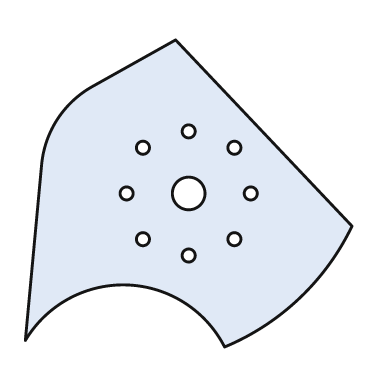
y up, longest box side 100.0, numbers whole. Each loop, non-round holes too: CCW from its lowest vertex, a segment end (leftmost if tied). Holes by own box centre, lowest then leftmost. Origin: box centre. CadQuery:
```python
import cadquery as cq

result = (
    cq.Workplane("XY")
    .moveTo(11.0, -47.0)
    .threePointArc((34.0, -32.0), (50.0, -10.0))
    .lineTo(-4.0, 47.0)
    .lineTo(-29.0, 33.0)
    .threePointArc((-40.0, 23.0), (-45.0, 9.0))
    .lineTo(-50.0, -45.0)
    .threePointArc((-19.0, -28.0), (11.0, -47.0))
    .close()
    .moveTo(0.0, -19.0)
    .circle(2.0)
    .moveTo(-14.0, -14.0)
    .circle(2.0)
    .moveTo(14.0, -14.0)
    .circle(2.0)
    .moveTo(-19.0, 0.0)
    .circle(2.0)
    .moveTo(0.0, 0.0)
    .circle(5.0)
    .moveTo(19.0, 0.0)
    .circle(2.0)
    .moveTo(-14.0, 14.0)
    .circle(2.0)
    .moveTo(14.0, 14.0)
    .circle(2.0)
    .moveTo(0.0, 19.0)
    .circle(2.0)
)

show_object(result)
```